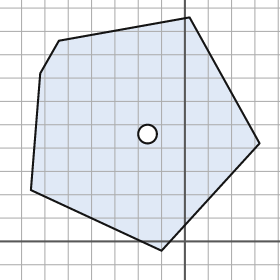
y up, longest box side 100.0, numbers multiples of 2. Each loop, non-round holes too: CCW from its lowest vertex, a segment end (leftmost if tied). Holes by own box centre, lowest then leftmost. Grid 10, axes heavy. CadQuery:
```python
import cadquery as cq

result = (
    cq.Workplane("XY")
    .moveTo(-10.0, -4.0)
    .lineTo(32.0, 42.0)
    .lineTo(2.0, 96.0)
    .lineTo(-54.0, 86.0)
    .lineTo(-62.0, 72.0)
    .lineTo(-66.0, 22.0)
    .close()
    .moveTo(-16.0, 46.0)
    .circle(4.0)
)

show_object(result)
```